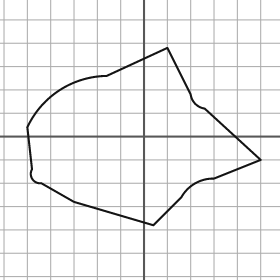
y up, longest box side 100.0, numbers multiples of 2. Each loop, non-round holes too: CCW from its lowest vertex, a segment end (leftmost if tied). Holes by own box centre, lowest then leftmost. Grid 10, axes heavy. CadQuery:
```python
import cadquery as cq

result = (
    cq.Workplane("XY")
    .moveTo(4.0, -38.0)
    .lineTo(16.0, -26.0)
    .threePointArc((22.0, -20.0), (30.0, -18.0))
    .lineTo(50.0, -10.0)
    .lineTo(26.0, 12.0)
    .threePointArc((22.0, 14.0), (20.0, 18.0))
    .lineTo(10.0, 38.0)
    .lineTo(-16.0, 26.0)
    .threePointArc((-36.0, 20.0), (-50.0, 4.0))
    .lineTo(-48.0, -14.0)
    .threePointArc((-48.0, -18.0), (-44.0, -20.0))
    .lineTo(-30.0, -28.0)
    .close()
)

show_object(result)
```